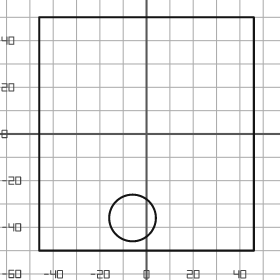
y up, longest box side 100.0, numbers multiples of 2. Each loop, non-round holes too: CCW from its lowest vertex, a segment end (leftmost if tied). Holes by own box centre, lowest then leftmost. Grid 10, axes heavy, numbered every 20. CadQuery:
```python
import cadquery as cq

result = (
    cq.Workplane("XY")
    .moveTo(-46.0, -50.0)
    .lineTo(46.0, -50.0)
    .lineTo(46.0, 50.0)
    .lineTo(-46.0, 50.0)
    .close()
    .moveTo(-6.0, -36.0)
    .circle(10.0)
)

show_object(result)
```